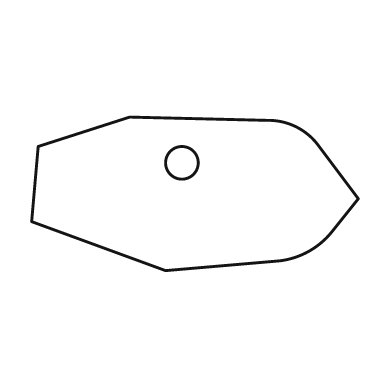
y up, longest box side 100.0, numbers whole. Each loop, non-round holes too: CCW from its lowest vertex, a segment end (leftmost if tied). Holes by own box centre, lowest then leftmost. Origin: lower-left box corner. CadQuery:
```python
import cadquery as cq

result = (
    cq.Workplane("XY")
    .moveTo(41.0, 0.0)
    .lineTo(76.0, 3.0)
    .threePointArc((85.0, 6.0), (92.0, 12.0))
    .lineTo(100.0, 22.0)
    .lineTo(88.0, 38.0)
    .threePointArc((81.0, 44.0), (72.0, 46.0))
    .lineTo(30.0, 47.0)
    .lineTo(2.0, 38.0)
    .lineTo(0.0, 15.0)
    .close()
    .moveTo(46.0, 33.0)
    .circle(5.0)
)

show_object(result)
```